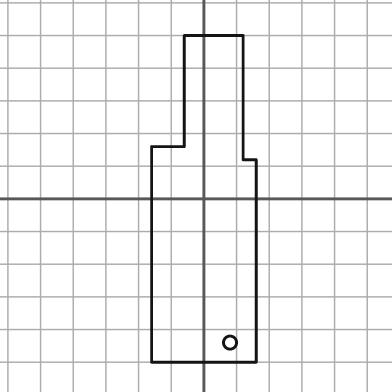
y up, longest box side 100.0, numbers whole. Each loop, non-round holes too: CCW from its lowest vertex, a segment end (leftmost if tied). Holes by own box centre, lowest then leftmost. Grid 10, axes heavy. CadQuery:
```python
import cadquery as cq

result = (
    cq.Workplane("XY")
    .moveTo(-16.0, -50.0)
    .lineTo(16.0, -50.0)
    .lineTo(16.0, 12.0)
    .lineTo(12.0, 12.0)
    .lineTo(12.0, 50.0)
    .lineTo(-6.0, 50.0)
    .lineTo(-6.0, 16.0)
    .lineTo(-16.0, 16.0)
    .close()
    .moveTo(8.0, -44.0)
    .circle(2.0)
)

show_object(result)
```